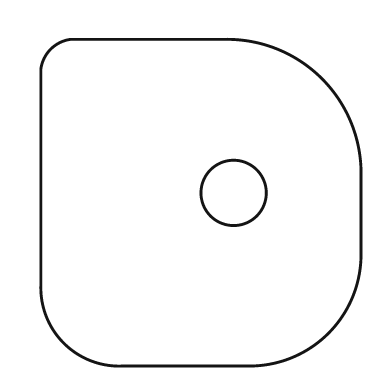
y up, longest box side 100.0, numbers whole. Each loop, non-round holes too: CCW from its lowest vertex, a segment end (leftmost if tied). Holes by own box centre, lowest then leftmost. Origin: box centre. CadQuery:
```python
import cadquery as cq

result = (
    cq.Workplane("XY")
    .moveTo(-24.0, -50.0)
    .lineTo(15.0, -50.0)
    .threePointArc((39.0, -40.0), (49.0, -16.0))
    .lineTo(49.0, 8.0)
    .threePointArc((37.0, 38.0), (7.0, 50.0))
    .lineTo(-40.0, 50.0)
    .threePointArc((-46.0, 47.0), (-49.0, 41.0))
    .lineTo(-49.0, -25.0)
    .threePointArc((-42.0, -43.0), (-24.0, -50.0))
    .close()
    .moveTo(10.0, 3.0)
    .circle(10.0)
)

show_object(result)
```